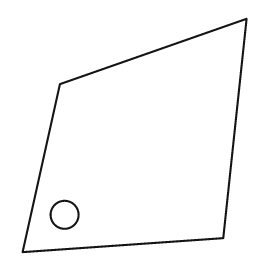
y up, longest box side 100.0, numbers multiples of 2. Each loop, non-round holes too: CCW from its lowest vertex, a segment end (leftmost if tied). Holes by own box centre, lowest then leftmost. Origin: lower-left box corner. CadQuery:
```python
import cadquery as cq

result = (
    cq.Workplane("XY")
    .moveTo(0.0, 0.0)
    .lineTo(86.0, 6.0)
    .lineTo(96.0, 100.0)
    .lineTo(16.0, 72.0)
    .close()
    .moveTo(18.0, 16.0)
    .circle(6.0)
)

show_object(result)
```